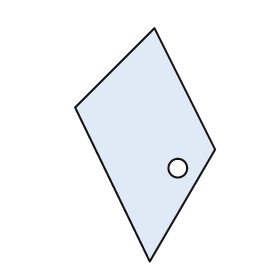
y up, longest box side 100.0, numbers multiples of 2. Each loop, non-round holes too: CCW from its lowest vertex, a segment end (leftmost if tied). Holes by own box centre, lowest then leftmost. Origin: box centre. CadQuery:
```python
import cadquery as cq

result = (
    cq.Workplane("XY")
    .moveTo(2.0, -50.0)
    .lineTo(30.0, -2.0)
    .lineTo(4.0, 50.0)
    .lineTo(-30.0, 16.0)
    .close()
    .moveTo(14.0, -10.0)
    .circle(4.0)
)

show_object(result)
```